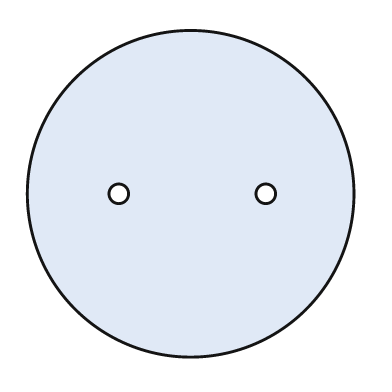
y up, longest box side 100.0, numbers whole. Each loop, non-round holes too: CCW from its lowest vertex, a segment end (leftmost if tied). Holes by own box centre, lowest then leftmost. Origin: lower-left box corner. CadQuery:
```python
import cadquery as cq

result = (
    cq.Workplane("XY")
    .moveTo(50.0, 50.0)
    .circle(50.0)
    .moveTo(28.0, 50.0)
    .circle(3.0)
    .moveTo(73.0, 50.0)
    .circle(3.0)
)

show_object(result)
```